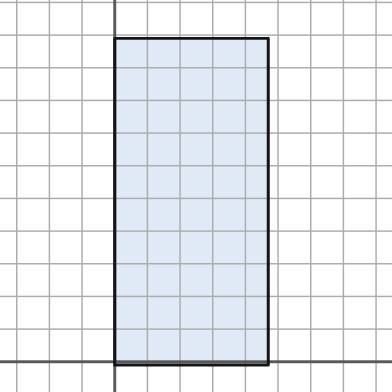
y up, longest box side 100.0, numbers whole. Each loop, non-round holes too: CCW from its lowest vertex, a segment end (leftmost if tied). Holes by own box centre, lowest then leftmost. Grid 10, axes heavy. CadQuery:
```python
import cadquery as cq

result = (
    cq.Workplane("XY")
    .moveTo(0.0, -1.0)
    .lineTo(47.0, -1.0)
    .lineTo(47.0, 99.0)
    .lineTo(0.0, 99.0)
    .close()
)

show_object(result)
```